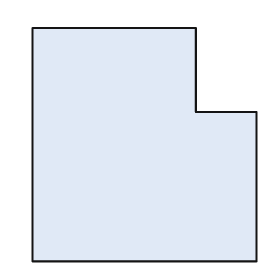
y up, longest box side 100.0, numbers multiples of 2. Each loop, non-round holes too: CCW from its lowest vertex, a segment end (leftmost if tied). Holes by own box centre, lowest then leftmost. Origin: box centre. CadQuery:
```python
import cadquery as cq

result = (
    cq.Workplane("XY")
    .moveTo(-48.0, -50.0)
    .lineTo(48.0, -50.0)
    .lineTo(48.0, 14.0)
    .lineTo(22.0, 14.0)
    .lineTo(22.0, 50.0)
    .lineTo(-48.0, 50.0)
    .close()
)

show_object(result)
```